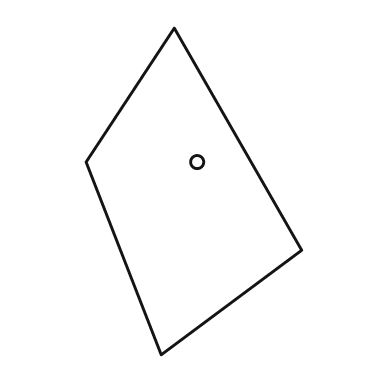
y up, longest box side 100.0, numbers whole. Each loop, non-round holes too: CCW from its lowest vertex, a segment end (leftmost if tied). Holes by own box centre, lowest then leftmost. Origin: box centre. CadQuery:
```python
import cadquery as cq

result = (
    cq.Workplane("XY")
    .moveTo(-10.0, -50.0)
    .lineTo(33.0, -18.0)
    .lineTo(-6.0, 50.0)
    .lineTo(-33.0, 9.0)
    .close()
    .moveTo(1.0, 9.0)
    .circle(2.0)
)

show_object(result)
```